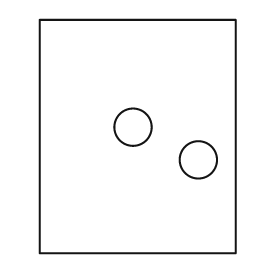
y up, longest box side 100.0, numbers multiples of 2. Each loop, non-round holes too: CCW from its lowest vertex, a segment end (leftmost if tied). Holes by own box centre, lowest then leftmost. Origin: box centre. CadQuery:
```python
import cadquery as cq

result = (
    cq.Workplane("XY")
    .moveTo(-42.0, -50.0)
    .lineTo(42.0, -50.0)
    .lineTo(42.0, 50.0)
    .lineTo(-42.0, 50.0)
    .close()
    .moveTo(26.0, -10.0)
    .circle(8.0)
    .moveTo(-2.0, 4.0)
    .circle(8.0)
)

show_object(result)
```